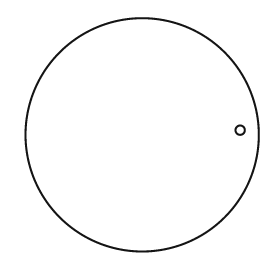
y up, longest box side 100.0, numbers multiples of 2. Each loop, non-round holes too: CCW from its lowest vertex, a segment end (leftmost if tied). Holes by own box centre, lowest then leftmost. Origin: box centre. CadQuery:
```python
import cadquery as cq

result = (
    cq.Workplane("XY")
    .moveTo(0.0, 0.0)
    .circle(50.0)
    .moveTo(42.0, 2.0)
    .circle(2.0)
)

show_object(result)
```